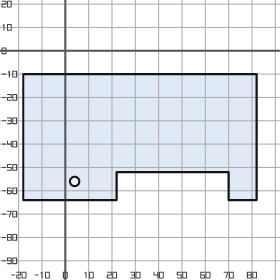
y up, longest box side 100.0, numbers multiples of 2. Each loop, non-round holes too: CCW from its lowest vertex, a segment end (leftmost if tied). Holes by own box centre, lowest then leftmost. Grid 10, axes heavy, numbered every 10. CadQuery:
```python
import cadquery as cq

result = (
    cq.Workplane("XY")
    .moveTo(-18.0, -64.0)
    .lineTo(22.0, -64.0)
    .lineTo(22.0, -52.0)
    .lineTo(70.0, -52.0)
    .lineTo(70.0, -64.0)
    .lineTo(82.0, -64.0)
    .lineTo(82.0, -10.0)
    .lineTo(-18.0, -10.0)
    .close()
    .moveTo(4.0, -56.0)
    .circle(2.0)
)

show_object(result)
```